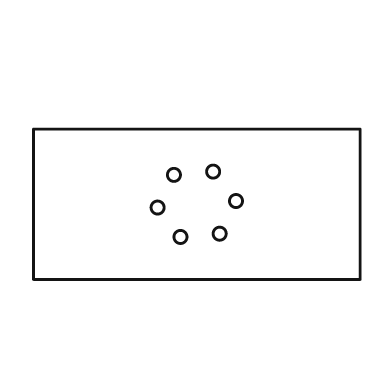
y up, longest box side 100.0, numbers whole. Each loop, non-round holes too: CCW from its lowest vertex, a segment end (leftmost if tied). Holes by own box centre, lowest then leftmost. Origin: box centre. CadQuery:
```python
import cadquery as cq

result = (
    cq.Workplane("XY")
    .moveTo(-50.0, -23.0)
    .lineTo(50.0, -23.0)
    .lineTo(50.0, 23.0)
    .lineTo(-50.0, 23.0)
    .close()
    .moveTo(-5.0, -10.0)
    .circle(2.0)
    .moveTo(7.0, -9.0)
    .circle(2.0)
    .moveTo(-12.0, -1.0)
    .circle(2.0)
    .moveTo(12.0, 1.0)
    .circle(2.0)
    .moveTo(-7.0, 9.0)
    .circle(2.0)
    .moveTo(5.0, 10.0)
    .circle(2.0)
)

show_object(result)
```